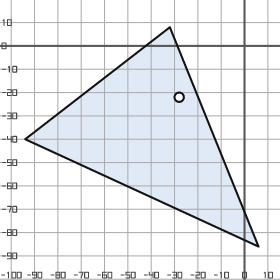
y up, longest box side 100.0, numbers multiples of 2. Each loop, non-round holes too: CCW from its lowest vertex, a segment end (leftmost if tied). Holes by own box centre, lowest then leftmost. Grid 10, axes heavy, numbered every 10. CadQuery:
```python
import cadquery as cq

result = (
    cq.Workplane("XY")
    .moveTo(6.0, -86.0)
    .lineTo(-32.0, 8.0)
    .lineTo(-94.0, -40.0)
    .close()
    .moveTo(-28.0, -22.0)
    .circle(2.0)
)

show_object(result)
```